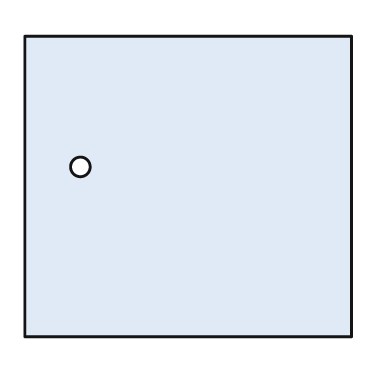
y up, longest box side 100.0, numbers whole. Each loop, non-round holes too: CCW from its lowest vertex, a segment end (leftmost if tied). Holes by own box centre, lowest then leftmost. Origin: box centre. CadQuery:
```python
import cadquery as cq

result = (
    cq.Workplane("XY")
    .moveTo(-50.0, -46.0)
    .lineTo(50.0, -46.0)
    .lineTo(50.0, 46.0)
    .lineTo(-50.0, 46.0)
    .close()
    .moveTo(-33.0, 6.0)
    .circle(3.0)
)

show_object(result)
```